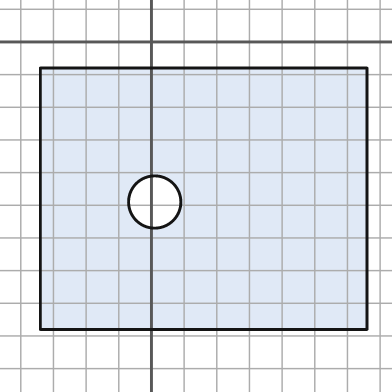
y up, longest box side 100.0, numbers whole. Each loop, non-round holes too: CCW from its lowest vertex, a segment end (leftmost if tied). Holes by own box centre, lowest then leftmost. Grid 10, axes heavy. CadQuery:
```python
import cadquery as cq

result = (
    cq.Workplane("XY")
    .moveTo(-34.0, -88.0)
    .lineTo(66.0, -88.0)
    .lineTo(66.0, -8.0)
    .lineTo(-34.0, -8.0)
    .close()
    .moveTo(1.0, -49.0)
    .circle(8.0)
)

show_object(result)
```